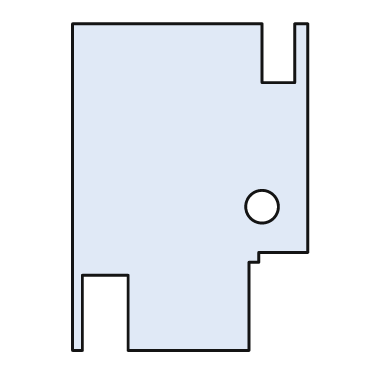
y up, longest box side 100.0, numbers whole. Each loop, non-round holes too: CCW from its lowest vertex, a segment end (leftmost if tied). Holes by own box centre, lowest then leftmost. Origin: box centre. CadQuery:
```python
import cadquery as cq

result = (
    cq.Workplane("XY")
    .moveTo(-36.0, -50.0)
    .lineTo(-33.0, -50.0)
    .lineTo(-33.0, -27.0)
    .lineTo(-19.0, -27.0)
    .lineTo(-19.0, -50.0)
    .lineTo(18.0, -50.0)
    .lineTo(18.0, -23.0)
    .lineTo(21.0, -23.0)
    .lineTo(21.0, -20.0)
    .lineTo(36.0, -20.0)
    .lineTo(36.0, 50.0)
    .lineTo(32.0, 50.0)
    .lineTo(32.0, 32.0)
    .lineTo(22.0, 32.0)
    .lineTo(22.0, 50.0)
    .lineTo(-36.0, 50.0)
    .close()
    .moveTo(22.0, -6.0)
    .circle(5.0)
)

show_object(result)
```